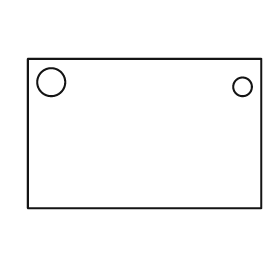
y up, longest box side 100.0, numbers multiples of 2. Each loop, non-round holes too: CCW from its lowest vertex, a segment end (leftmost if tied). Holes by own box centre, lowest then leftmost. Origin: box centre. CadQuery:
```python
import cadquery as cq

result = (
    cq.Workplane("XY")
    .moveTo(-50.0, -32.0)
    .lineTo(50.0, -32.0)
    .lineTo(50.0, 32.0)
    .lineTo(-50.0, 32.0)
    .close()
    .moveTo(42.0, 20.0)
    .circle(4.0)
    .moveTo(-40.0, 22.0)
    .circle(6.0)
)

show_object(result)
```